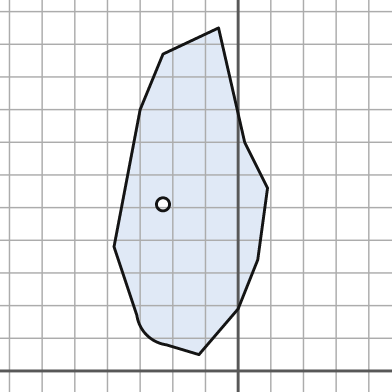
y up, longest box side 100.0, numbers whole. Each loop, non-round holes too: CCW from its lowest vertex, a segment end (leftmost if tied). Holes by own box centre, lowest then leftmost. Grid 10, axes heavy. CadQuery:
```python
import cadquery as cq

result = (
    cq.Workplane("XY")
    .moveTo(-12.0, 5.0)
    .lineTo(0.0, 19.0)
    .lineTo(6.0, 34.0)
    .lineTo(9.0, 56.0)
    .lineTo(2.0, 70.0)
    .lineTo(-6.0, 105.0)
    .lineTo(-23.0, 97.0)
    .lineTo(-30.0, 80.0)
    .lineTo(-38.0, 38.0)
    .lineTo(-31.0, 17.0)
    .threePointArc((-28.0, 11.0), (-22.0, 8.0))
    .close()
    .moveTo(-23.0, 51.0)
    .circle(2.0)
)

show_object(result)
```